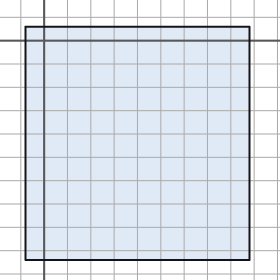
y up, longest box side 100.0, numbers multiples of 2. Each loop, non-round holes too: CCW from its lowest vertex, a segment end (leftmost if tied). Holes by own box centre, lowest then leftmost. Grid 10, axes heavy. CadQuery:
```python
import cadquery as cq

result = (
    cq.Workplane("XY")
    .moveTo(-8.0, -94.0)
    .lineTo(88.0, -94.0)
    .lineTo(88.0, 6.0)
    .lineTo(-8.0, 6.0)
    .close()
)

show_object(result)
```